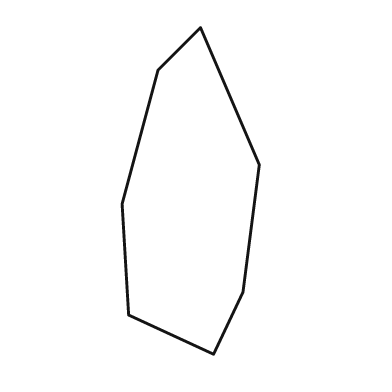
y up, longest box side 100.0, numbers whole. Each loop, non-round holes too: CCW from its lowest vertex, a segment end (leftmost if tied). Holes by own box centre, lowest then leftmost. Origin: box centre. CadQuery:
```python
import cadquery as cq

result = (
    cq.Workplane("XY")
    .moveTo(7.0, -50.0)
    .lineTo(16.0, -31.0)
    .lineTo(21.0, 8.0)
    .lineTo(3.0, 50.0)
    .lineTo(-10.0, 37.0)
    .lineTo(-21.0, -4.0)
    .lineTo(-19.0, -38.0)
    .close()
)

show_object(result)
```